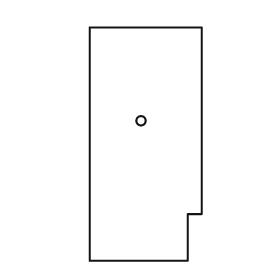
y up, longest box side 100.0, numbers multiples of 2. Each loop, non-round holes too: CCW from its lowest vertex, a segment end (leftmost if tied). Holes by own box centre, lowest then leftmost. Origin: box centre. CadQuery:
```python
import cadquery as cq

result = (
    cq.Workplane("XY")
    .moveTo(-24.0, -50.0)
    .lineTo(18.0, -50.0)
    .lineTo(18.0, -30.0)
    .lineTo(24.0, -30.0)
    .lineTo(24.0, 50.0)
    .lineTo(-24.0, 50.0)
    .close()
    .moveTo(-2.0, 10.0)
    .circle(2.0)
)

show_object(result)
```